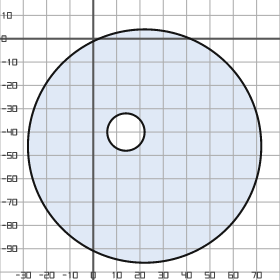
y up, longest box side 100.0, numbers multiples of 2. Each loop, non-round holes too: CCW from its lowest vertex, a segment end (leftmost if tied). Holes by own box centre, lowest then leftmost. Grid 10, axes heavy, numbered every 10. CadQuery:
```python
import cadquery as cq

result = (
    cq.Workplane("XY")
    .moveTo(22.0, -46.0)
    .circle(50.0)
    .moveTo(14.0, -40.0)
    .circle(8.0)
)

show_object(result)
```